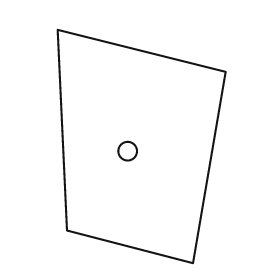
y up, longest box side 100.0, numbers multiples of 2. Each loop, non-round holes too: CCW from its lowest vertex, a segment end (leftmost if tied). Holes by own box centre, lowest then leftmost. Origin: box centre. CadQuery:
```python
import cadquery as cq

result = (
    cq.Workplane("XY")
    .moveTo(22.0, -50.0)
    .lineTo(36.0, 32.0)
    .lineTo(-36.0, 50.0)
    .lineTo(-32.0, -36.0)
    .close()
    .moveTo(-6.0, -2.0)
    .circle(4.0)
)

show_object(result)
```